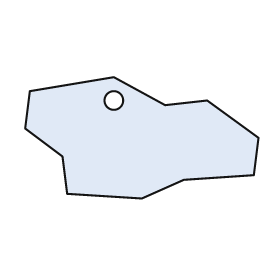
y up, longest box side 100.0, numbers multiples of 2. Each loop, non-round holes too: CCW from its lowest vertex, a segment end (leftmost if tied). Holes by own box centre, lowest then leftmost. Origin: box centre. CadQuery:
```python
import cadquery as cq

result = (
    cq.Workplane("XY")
    .moveTo(0.0, -26.0)
    .lineTo(18.0, -18.0)
    .lineTo(48.0, -16.0)
    .lineTo(50.0, 0.0)
    .lineTo(28.0, 16.0)
    .lineTo(10.0, 14.0)
    .lineTo(-12.0, 26.0)
    .lineTo(-48.0, 20.0)
    .lineTo(-50.0, 4.0)
    .lineTo(-34.0, -8.0)
    .lineTo(-32.0, -24.0)
    .close()
    .moveTo(-12.0, 16.0)
    .circle(4.0)
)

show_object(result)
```